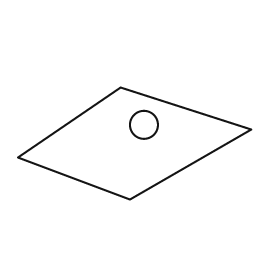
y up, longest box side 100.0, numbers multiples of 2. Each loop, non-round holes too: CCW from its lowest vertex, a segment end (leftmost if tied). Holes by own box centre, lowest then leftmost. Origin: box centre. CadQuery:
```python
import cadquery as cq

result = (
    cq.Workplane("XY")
    .moveTo(-2.0, -24.0)
    .lineTo(50.0, 6.0)
    .lineTo(-6.0, 24.0)
    .lineTo(-50.0, -6.0)
    .close()
    .moveTo(4.0, 8.0)
    .circle(6.0)
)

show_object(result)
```